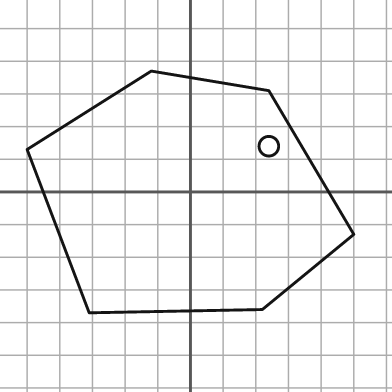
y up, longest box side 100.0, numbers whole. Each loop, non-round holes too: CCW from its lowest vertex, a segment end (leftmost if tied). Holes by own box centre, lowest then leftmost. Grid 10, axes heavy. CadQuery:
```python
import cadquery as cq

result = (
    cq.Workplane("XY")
    .moveTo(-31.0, -37.0)
    .lineTo(22.0, -36.0)
    .lineTo(50.0, -13.0)
    .lineTo(24.0, 31.0)
    .lineTo(-12.0, 37.0)
    .lineTo(-50.0, 13.0)
    .close()
    .moveTo(24.0, 14.0)
    .circle(3.0)
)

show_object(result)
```